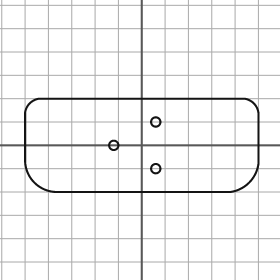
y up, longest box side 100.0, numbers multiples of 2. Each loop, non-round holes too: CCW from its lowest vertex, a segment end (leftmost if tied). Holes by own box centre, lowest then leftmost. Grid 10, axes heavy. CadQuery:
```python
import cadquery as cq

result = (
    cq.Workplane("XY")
    .moveTo(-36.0, -20.0)
    .lineTo(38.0, -20.0)
    .threePointArc((46.0, -16.0), (50.0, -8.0))
    .lineTo(50.0, 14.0)
    .threePointArc((48.0, 18.0), (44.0, 20.0))
    .lineTo(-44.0, 20.0)
    .threePointArc((-48.0, 18.0), (-50.0, 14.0))
    .lineTo(-50.0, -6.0)
    .threePointArc((-46.0, -16.0), (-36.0, -20.0))
    .close()
    .moveTo(6.0, -10.0)
    .circle(2.0)
    .moveTo(-12.0, 0.0)
    .circle(2.0)
    .moveTo(6.0, 10.0)
    .circle(2.0)
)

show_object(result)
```